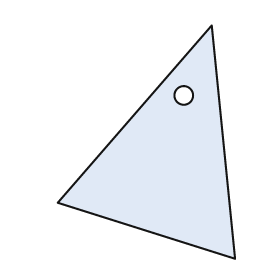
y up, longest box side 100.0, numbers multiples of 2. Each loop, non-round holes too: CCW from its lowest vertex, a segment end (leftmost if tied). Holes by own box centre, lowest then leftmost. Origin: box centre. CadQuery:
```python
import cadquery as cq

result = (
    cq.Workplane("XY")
    .moveTo(38.0, -50.0)
    .lineTo(28.0, 50.0)
    .lineTo(-38.0, -26.0)
    .close()
    .moveTo(16.0, 20.0)
    .circle(4.0)
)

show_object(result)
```